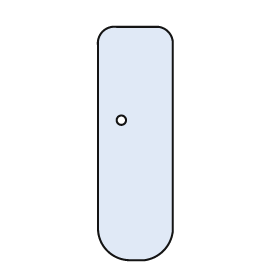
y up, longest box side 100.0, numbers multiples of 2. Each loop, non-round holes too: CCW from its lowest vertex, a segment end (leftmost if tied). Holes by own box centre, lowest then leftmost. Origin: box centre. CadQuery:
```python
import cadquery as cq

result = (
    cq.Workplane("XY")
    .moveTo(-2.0, -50.0)
    .lineTo(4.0, -50.0)
    .threePointArc((12.0, -46.0), (16.0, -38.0))
    .lineTo(16.0, 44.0)
    .threePointArc((14.0, 48.0), (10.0, 50.0))
    .lineTo(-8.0, 50.0)
    .threePointArc((-14.0, 48.0), (-16.0, 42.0))
    .lineTo(-16.0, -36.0)
    .threePointArc((-12.0, -46.0), (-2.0, -50.0))
    .close()
    .moveTo(-6.0, 10.0)
    .circle(2.0)
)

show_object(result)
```